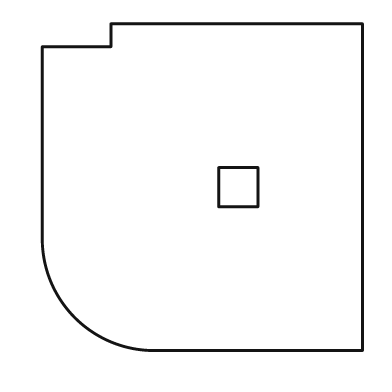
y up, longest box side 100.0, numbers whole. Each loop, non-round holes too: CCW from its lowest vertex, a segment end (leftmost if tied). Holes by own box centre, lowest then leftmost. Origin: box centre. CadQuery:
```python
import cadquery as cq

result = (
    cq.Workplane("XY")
    .moveTo(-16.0, -50.0)
    .lineTo(49.0, -50.0)
    .lineTo(49.0, 50.0)
    .lineTo(-28.0, 50.0)
    .lineTo(-28.0, 43.0)
    .lineTo(-49.0, 43.0)
    .lineTo(-49.0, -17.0)
    .threePointArc((-39.0, -40.0), (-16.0, -50.0))
    .close()
    .moveTo(5.0, -6.0)
    .lineTo(17.0, -6.0)
    .lineTo(17.0, 6.0)
    .lineTo(5.0, 6.0)
    .close()
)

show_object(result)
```